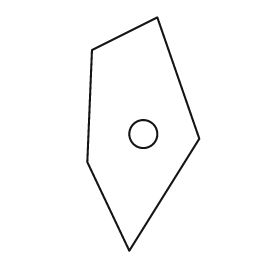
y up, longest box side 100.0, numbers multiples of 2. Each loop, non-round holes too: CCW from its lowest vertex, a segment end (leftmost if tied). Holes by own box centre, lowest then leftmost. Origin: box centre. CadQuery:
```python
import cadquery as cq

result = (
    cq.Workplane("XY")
    .moveTo(-6.0, -50.0)
    .lineTo(24.0, -2.0)
    .lineTo(6.0, 50.0)
    .lineTo(-22.0, 36.0)
    .lineTo(-24.0, -12.0)
    .close()
    .moveTo(0.0, 0.0)
    .circle(6.0)
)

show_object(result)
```